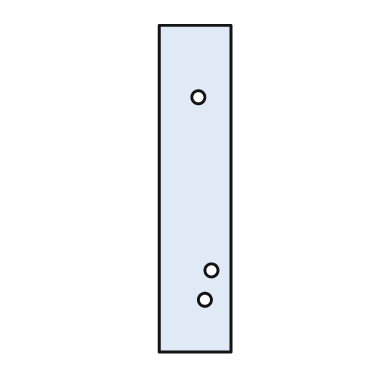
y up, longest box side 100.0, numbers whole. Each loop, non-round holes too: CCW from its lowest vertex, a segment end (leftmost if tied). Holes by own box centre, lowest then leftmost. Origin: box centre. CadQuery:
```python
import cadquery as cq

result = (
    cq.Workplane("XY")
    .moveTo(-11.0, -50.0)
    .lineTo(11.0, -50.0)
    .lineTo(11.0, 50.0)
    .lineTo(-11.0, 50.0)
    .close()
    .moveTo(3.0, -34.0)
    .circle(2.0)
    .moveTo(5.0, -25.0)
    .circle(2.0)
    .moveTo(1.0, 28.0)
    .circle(2.0)
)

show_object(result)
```